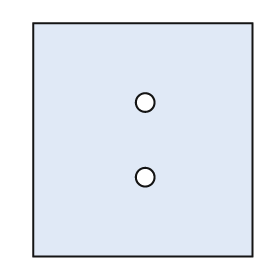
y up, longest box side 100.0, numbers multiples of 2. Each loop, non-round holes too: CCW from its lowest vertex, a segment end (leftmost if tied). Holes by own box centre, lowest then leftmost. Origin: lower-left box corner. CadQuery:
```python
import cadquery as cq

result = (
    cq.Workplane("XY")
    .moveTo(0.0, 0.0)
    .lineTo(94.0, 0.0)
    .lineTo(94.0, 100.0)
    .lineTo(0.0, 100.0)
    .close()
    .moveTo(48.0, 34.0)
    .circle(4.0)
    .moveTo(48.0, 66.0)
    .circle(4.0)
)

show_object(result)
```